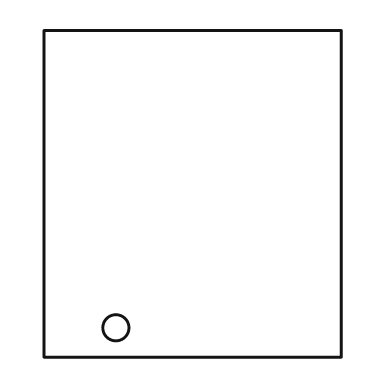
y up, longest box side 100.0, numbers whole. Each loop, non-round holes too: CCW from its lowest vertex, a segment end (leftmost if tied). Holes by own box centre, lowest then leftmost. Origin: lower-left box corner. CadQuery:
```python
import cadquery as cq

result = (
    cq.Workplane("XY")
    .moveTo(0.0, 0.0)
    .lineTo(91.0, 0.0)
    .lineTo(91.0, 100.0)
    .lineTo(0.0, 100.0)
    .close()
    .moveTo(22.0, 9.0)
    .circle(4.0)
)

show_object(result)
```